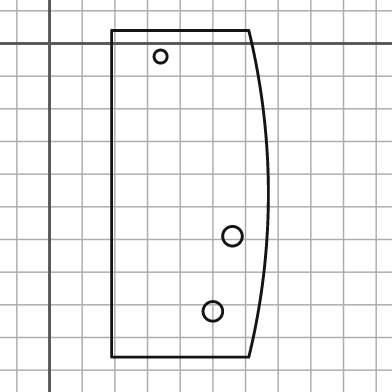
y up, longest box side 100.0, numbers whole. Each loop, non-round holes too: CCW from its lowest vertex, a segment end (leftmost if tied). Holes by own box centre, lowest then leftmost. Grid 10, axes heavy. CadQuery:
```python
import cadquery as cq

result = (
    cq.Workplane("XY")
    .moveTo(19.0, -96.0)
    .lineTo(61.0, -96.0)
    .threePointArc((67.0, -46.0), (61.0, 4.0))
    .lineTo(19.0, 4.0)
    .close()
    .moveTo(50.0, -82.0)
    .circle(3.0)
    .moveTo(56.0, -59.0)
    .circle(3.0)
    .moveTo(34.0, -4.0)
    .circle(2.0)
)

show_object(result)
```